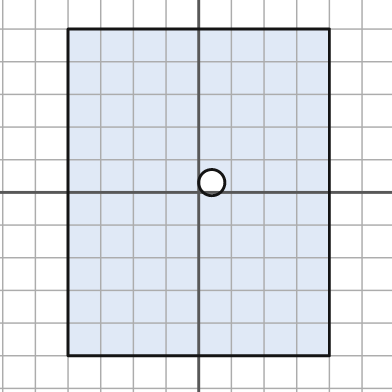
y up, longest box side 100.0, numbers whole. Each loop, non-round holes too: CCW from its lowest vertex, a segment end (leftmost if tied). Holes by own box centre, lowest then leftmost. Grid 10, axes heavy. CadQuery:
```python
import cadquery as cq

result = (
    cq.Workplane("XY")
    .moveTo(-40.0, -50.0)
    .lineTo(40.0, -50.0)
    .lineTo(40.0, 50.0)
    .lineTo(-40.0, 50.0)
    .close()
    .moveTo(4.0, 3.0)
    .circle(4.0)
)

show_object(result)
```